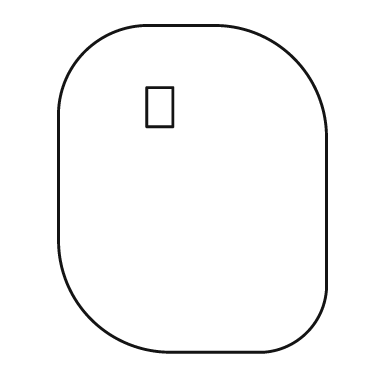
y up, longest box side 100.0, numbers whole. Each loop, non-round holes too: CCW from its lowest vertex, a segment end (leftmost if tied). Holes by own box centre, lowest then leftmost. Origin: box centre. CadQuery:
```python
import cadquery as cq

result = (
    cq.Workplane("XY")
    .moveTo(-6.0, -50.0)
    .lineTo(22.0, -50.0)
    .threePointArc((35.0, -44.0), (41.0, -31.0))
    .lineTo(41.0, 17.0)
    .threePointArc((31.0, 40.0), (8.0, 50.0))
    .lineTo(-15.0, 50.0)
    .threePointArc((-33.0, 42.0), (-41.0, 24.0))
    .lineTo(-41.0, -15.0)
    .threePointArc((-31.0, -40.0), (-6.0, -50.0))
    .close()
    .moveTo(-14.0, 19.0)
    .lineTo(-6.0, 19.0)
    .lineTo(-6.0, 31.0)
    .lineTo(-14.0, 31.0)
    .close()
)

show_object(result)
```